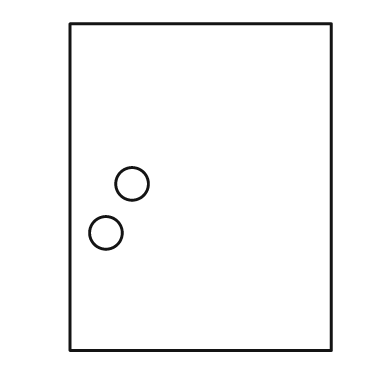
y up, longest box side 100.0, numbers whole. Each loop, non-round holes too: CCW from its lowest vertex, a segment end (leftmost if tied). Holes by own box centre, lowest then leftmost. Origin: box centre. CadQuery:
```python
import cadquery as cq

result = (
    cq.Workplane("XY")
    .moveTo(-40.0, -50.0)
    .lineTo(40.0, -50.0)
    .lineTo(40.0, 50.0)
    .lineTo(-40.0, 50.0)
    .close()
    .moveTo(-29.0, -14.0)
    .circle(5.0)
    .moveTo(-21.0, 1.0)
    .circle(5.0)
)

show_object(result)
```